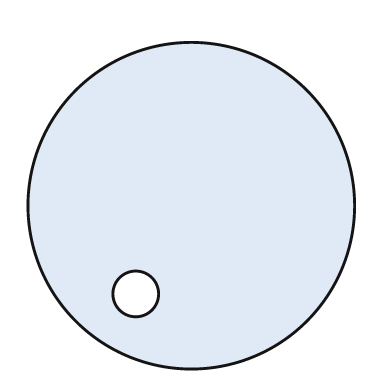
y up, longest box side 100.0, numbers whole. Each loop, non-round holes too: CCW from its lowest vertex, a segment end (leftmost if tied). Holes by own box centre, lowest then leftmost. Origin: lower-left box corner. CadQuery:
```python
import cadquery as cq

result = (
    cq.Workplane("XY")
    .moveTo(50.0, 50.0)
    .circle(50.0)
    .moveTo(33.0, 23.0)
    .circle(7.0)
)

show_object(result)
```